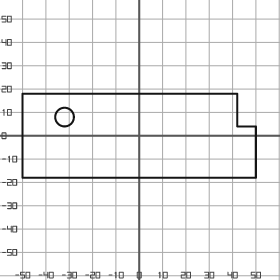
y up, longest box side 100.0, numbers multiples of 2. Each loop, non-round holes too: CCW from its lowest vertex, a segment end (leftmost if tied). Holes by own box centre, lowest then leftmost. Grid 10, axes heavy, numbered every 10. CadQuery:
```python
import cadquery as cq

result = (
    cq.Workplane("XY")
    .moveTo(-50.0, -18.0)
    .lineTo(50.0, -18.0)
    .lineTo(50.0, 4.0)
    .lineTo(42.0, 4.0)
    .lineTo(42.0, 18.0)
    .lineTo(-50.0, 18.0)
    .close()
    .moveTo(-32.0, 8.0)
    .circle(4.0)
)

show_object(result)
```